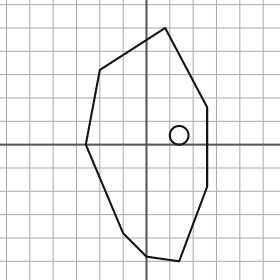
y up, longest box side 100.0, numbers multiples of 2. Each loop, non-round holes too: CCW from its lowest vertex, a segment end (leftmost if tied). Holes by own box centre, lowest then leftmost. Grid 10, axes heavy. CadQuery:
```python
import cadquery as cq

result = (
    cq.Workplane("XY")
    .moveTo(14.0, -50.0)
    .lineTo(26.0, -18.0)
    .lineTo(26.0, 16.0)
    .lineTo(8.0, 50.0)
    .lineTo(-20.0, 32.0)
    .lineTo(-26.0, 0.0)
    .lineTo(-10.0, -38.0)
    .lineTo(0.0, -48.0)
    .close()
    .moveTo(14.0, 4.0)
    .circle(4.0)
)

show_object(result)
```